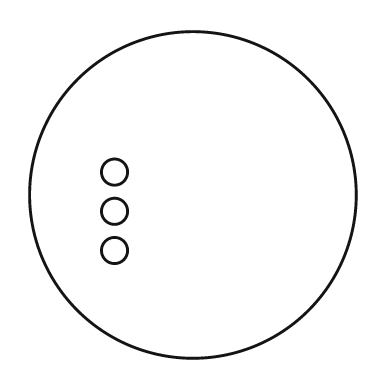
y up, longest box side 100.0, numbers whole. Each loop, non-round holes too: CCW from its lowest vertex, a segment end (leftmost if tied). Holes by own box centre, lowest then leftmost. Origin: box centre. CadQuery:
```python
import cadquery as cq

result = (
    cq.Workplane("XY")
    .moveTo(0.0, 0.0)
    .circle(50.0)
    .moveTo(-24.0, -17.0)
    .circle(4.0)
    .moveTo(-24.0, -5.0)
    .circle(4.0)
    .moveTo(-24.0, 7.0)
    .circle(4.0)
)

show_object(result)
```